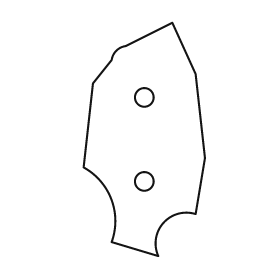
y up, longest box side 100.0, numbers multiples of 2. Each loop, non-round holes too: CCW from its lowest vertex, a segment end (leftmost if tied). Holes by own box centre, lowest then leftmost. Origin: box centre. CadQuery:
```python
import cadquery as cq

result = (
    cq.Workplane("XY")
    .moveTo(6.0, -50.0)
    .threePointArc((8.0, -36.0), (22.0, -32.0))
    .lineTo(26.0, -8.0)
    .lineTo(22.0, 28.0)
    .lineTo(12.0, 50.0)
    .lineTo(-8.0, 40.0)
    .threePointArc((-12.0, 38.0), (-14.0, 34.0))
    .lineTo(-22.0, 24.0)
    .lineTo(-26.0, -12.0)
    .threePointArc((-14.0, -26.0), (-14.0, -44.0))
    .close()
    .moveTo(0.0, -18.0)
    .circle(4.0)
    .moveTo(0.0, 18.0)
    .circle(4.0)
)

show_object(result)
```